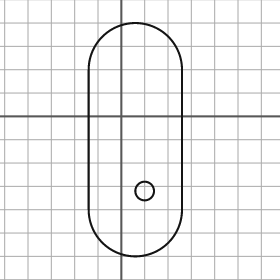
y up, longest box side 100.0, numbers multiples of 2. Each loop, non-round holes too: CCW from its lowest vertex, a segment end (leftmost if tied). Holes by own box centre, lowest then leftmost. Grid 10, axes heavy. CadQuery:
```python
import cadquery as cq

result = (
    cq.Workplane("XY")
    .moveTo(-14.0, -40.0)
    .threePointArc((6.0, -60.0), (26.0, -40.0))
    .lineTo(26.0, 20.0)
    .threePointArc((6.0, 40.0), (-14.0, 20.0))
    .close()
    .moveTo(10.0, -32.0)
    .circle(4.0)
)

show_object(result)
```